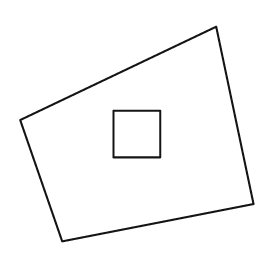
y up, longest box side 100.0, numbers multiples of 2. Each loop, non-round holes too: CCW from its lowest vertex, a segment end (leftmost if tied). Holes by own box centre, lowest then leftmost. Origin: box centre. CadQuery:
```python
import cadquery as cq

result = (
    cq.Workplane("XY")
    .moveTo(-32.0, -46.0)
    .lineTo(50.0, -30.0)
    .lineTo(34.0, 46.0)
    .lineTo(-50.0, 6.0)
    .close()
    .moveTo(-10.0, -10.0)
    .lineTo(10.0, -10.0)
    .lineTo(10.0, 10.0)
    .lineTo(-10.0, 10.0)
    .close()
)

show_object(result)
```